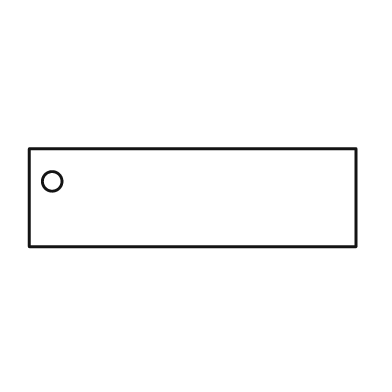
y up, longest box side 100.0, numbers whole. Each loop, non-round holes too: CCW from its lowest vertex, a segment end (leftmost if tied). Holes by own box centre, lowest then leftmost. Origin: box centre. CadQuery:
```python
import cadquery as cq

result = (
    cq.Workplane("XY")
    .moveTo(-50.0, -15.0)
    .lineTo(50.0, -15.0)
    .lineTo(50.0, 15.0)
    .lineTo(-50.0, 15.0)
    .close()
    .moveTo(-43.0, 5.0)
    .circle(3.0)
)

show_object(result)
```